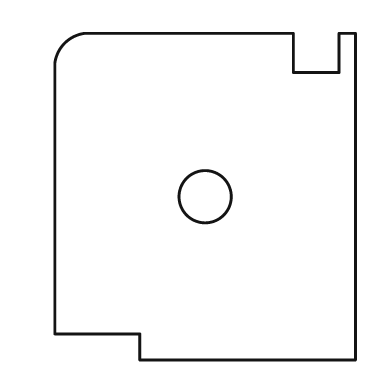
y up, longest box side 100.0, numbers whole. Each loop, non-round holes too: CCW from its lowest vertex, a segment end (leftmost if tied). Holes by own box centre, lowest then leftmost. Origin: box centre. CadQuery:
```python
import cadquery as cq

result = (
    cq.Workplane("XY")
    .moveTo(-20.0, -50.0)
    .lineTo(46.0, -50.0)
    .lineTo(46.0, 50.0)
    .lineTo(41.0, 50.0)
    .lineTo(41.0, 38.0)
    .lineTo(27.0, 38.0)
    .lineTo(27.0, 50.0)
    .lineTo(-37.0, 50.0)
    .threePointArc((-43.0, 47.0), (-46.0, 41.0))
    .lineTo(-46.0, -42.0)
    .lineTo(-20.0, -42.0)
    .close()
    .moveTo(0.0, 0.0)
    .circle(8.0)
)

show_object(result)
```